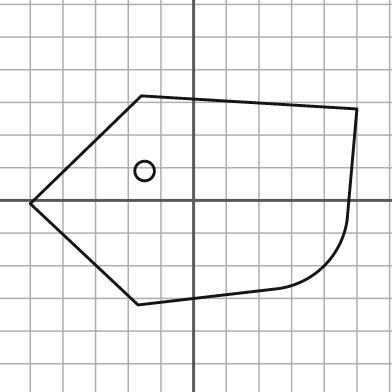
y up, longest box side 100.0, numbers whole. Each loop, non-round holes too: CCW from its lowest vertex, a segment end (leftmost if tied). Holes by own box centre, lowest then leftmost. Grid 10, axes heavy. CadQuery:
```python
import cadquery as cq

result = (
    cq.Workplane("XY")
    .moveTo(-17.0, -32.0)
    .lineTo(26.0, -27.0)
    .threePointArc((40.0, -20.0), (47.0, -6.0))
    .lineTo(50.0, 28.0)
    .lineTo(-16.0, 32.0)
    .lineTo(-50.0, -1.0)
    .close()
    .moveTo(-15.0, 9.0)
    .circle(3.0)
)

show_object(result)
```